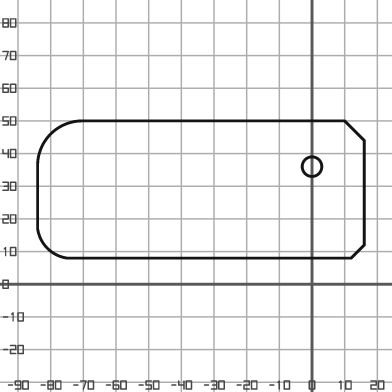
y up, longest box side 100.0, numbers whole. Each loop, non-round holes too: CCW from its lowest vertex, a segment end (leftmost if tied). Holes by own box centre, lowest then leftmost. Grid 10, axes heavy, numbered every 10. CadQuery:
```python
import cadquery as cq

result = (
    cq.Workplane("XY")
    .moveTo(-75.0, 8.0)
    .lineTo(12.0, 8.0)
    .lineTo(16.0, 12.0)
    .lineTo(16.0, 44.0)
    .lineTo(10.0, 50.0)
    .lineTo(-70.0, 50.0)
    .threePointArc((-80.0, 46.0), (-84.0, 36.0))
    .lineTo(-84.0, 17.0)
    .threePointArc((-81.0, 11.0), (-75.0, 8.0))
    .close()
    .moveTo(0.0, 36.0)
    .circle(3.0)
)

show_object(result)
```